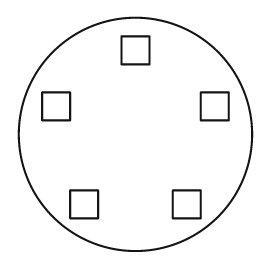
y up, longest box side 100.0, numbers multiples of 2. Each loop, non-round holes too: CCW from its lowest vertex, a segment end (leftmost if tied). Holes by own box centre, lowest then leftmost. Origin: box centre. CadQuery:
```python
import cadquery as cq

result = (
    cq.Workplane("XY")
    .moveTo(0.0, 0.0)
    .circle(50.0)
    .moveTo(-28.0, -36.0)
    .lineTo(-16.0, -36.0)
    .lineTo(-16.0, -24.0)
    .lineTo(-28.0, -24.0)
    .close()
    .moveTo(16.0, -36.0)
    .lineTo(28.0, -36.0)
    .lineTo(28.0, -24.0)
    .lineTo(16.0, -24.0)
    .close()
    .moveTo(-40.0, 6.0)
    .lineTo(-28.0, 6.0)
    .lineTo(-28.0, 18.0)
    .lineTo(-40.0, 18.0)
    .close()
    .moveTo(28.0, 6.0)
    .lineTo(40.0, 6.0)
    .lineTo(40.0, 18.0)
    .lineTo(28.0, 18.0)
    .close()
    .moveTo(-6.0, 30.0)
    .lineTo(6.0, 30.0)
    .lineTo(6.0, 42.0)
    .lineTo(-6.0, 42.0)
    .close()
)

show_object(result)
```